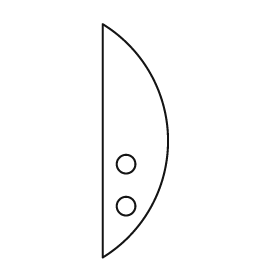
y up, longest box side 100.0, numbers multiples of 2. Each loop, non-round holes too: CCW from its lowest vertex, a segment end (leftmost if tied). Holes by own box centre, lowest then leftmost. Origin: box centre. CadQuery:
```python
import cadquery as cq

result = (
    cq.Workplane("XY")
    .moveTo(-14.0, -50.0)
    .threePointArc((14.0, 0.0), (-14.0, 50.0))
    .close()
    .moveTo(-4.0, -28.0)
    .circle(4.0)
    .moveTo(-4.0, -10.0)
    .circle(4.0)
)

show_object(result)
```